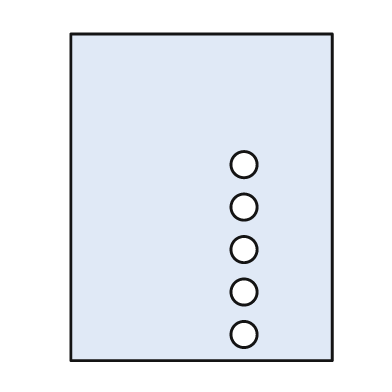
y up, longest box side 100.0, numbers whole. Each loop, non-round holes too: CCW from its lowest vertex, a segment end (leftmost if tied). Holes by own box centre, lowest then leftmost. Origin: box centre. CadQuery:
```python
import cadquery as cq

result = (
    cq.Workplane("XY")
    .moveTo(-40.0, -50.0)
    .lineTo(40.0, -50.0)
    .lineTo(40.0, 50.0)
    .lineTo(-40.0, 50.0)
    .close()
    .moveTo(13.0, -42.0)
    .circle(4.0)
    .moveTo(13.0, -29.0)
    .circle(4.0)
    .moveTo(13.0, -16.0)
    .circle(4.0)
    .moveTo(13.0, -3.0)
    .circle(4.0)
    .moveTo(13.0, 10.0)
    .circle(4.0)
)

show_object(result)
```